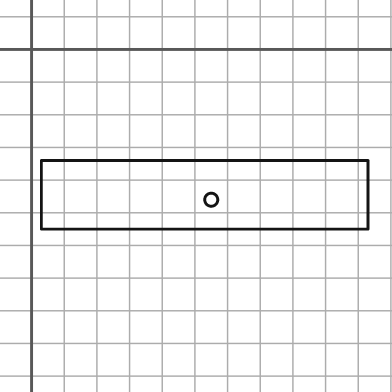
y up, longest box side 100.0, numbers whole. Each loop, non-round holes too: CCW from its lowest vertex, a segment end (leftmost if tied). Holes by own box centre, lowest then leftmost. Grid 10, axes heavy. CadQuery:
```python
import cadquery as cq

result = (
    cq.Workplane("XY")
    .moveTo(3.0, -55.0)
    .lineTo(103.0, -55.0)
    .lineTo(103.0, -34.0)
    .lineTo(3.0, -34.0)
    .close()
    .moveTo(55.0, -46.0)
    .circle(2.0)
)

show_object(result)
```